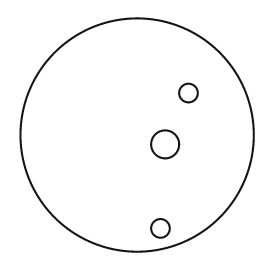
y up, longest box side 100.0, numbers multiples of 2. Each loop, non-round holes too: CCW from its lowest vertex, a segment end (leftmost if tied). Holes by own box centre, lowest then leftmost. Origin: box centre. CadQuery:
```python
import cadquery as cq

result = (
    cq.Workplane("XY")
    .moveTo(0.0, 0.0)
    .circle(50.0)
    .moveTo(10.0, -40.0)
    .circle(4.0)
    .moveTo(12.0, -4.0)
    .circle(6.0)
    .moveTo(22.0, 18.0)
    .circle(4.0)
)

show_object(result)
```